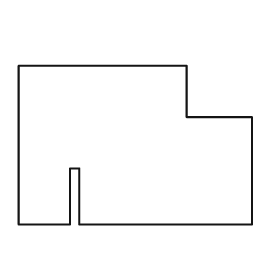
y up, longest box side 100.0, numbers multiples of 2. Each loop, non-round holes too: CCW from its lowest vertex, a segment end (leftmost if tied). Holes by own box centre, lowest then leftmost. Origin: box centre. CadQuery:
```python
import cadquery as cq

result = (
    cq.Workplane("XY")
    .moveTo(-50.0, -34.0)
    .lineTo(-28.0, -34.0)
    .lineTo(-28.0, -10.0)
    .lineTo(-24.0, -10.0)
    .lineTo(-24.0, -34.0)
    .lineTo(50.0, -34.0)
    .lineTo(50.0, 12.0)
    .lineTo(22.0, 12.0)
    .lineTo(22.0, 34.0)
    .lineTo(-50.0, 34.0)
    .close()
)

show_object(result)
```